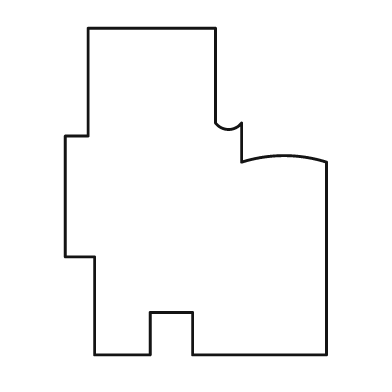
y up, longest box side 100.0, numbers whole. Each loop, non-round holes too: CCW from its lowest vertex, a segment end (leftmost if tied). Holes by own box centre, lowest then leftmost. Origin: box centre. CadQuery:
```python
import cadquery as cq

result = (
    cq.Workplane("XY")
    .moveTo(-31.0, -50.0)
    .lineTo(-14.0, -50.0)
    .lineTo(-14.0, -37.0)
    .lineTo(-1.0, -37.0)
    .lineTo(-1.0, -50.0)
    .lineTo(40.0, -50.0)
    .lineTo(40.0, 9.0)
    .threePointArc((27.0, 11.0), (14.0, 9.0))
    .lineTo(14.0, 21.0)
    .threePointArc((10.0, 19.0), (6.0, 21.0))
    .lineTo(6.0, 50.0)
    .lineTo(-33.0, 50.0)
    .lineTo(-33.0, 17.0)
    .lineTo(-40.0, 17.0)
    .lineTo(-40.0, -20.0)
    .lineTo(-31.0, -20.0)
    .close()
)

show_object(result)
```